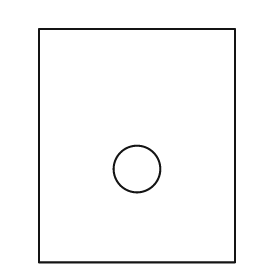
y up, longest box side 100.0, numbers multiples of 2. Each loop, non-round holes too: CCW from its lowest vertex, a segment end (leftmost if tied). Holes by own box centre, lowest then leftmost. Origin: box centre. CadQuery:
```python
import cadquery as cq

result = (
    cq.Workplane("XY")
    .moveTo(-42.0, -50.0)
    .lineTo(42.0, -50.0)
    .lineTo(42.0, 50.0)
    .lineTo(-42.0, 50.0)
    .close()
    .moveTo(0.0, -10.0)
    .circle(10.0)
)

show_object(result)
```